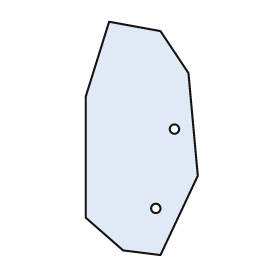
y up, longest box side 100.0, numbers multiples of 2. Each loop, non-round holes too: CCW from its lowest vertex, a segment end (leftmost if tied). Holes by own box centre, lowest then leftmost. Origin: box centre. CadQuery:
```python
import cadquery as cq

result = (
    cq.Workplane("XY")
    .moveTo(8.0, -50.0)
    .lineTo(24.0, -16.0)
    .lineTo(20.0, 28.0)
    .lineTo(8.0, 46.0)
    .lineTo(-14.0, 50.0)
    .lineTo(-24.0, 18.0)
    .lineTo(-24.0, -34.0)
    .lineTo(-8.0, -48.0)
    .close()
    .moveTo(6.0, -30.0)
    .circle(2.0)
    .moveTo(14.0, 4.0)
    .circle(2.0)
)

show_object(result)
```